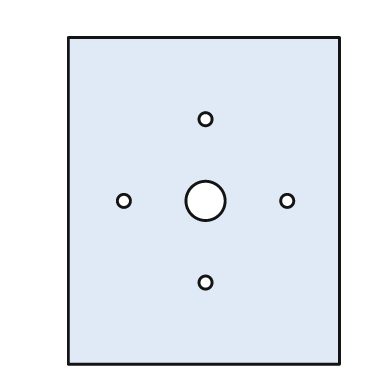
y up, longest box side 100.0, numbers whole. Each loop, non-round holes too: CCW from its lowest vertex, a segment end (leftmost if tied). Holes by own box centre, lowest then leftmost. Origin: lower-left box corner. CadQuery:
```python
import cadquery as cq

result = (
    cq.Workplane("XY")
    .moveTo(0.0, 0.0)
    .lineTo(83.0, 0.0)
    .lineTo(83.0, 100.0)
    .lineTo(0.0, 100.0)
    .close()
    .moveTo(42.0, 25.0)
    .circle(2.0)
    .moveTo(17.0, 50.0)
    .circle(2.0)
    .moveTo(42.0, 50.0)
    .circle(6.0)
    .moveTo(67.0, 50.0)
    .circle(2.0)
    .moveTo(42.0, 75.0)
    .circle(2.0)
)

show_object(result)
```